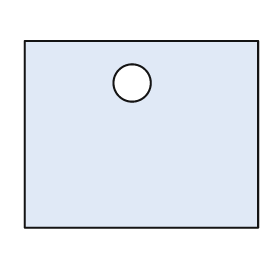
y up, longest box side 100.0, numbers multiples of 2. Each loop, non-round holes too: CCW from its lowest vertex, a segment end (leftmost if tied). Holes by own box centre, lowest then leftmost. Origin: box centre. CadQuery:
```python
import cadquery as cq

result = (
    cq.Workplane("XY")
    .moveTo(-50.0, -40.0)
    .lineTo(50.0, -40.0)
    .lineTo(50.0, 40.0)
    .lineTo(-50.0, 40.0)
    .close()
    .moveTo(-4.0, 22.0)
    .circle(8.0)
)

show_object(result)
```